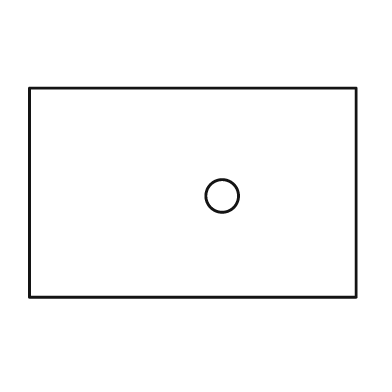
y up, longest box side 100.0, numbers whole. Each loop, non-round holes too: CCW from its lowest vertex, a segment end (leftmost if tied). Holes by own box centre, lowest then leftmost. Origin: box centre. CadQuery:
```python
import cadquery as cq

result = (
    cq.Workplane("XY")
    .moveTo(-50.0, -32.0)
    .lineTo(50.0, -32.0)
    .lineTo(50.0, 32.0)
    .lineTo(-50.0, 32.0)
    .close()
    .moveTo(9.0, -1.0)
    .circle(5.0)
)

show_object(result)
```